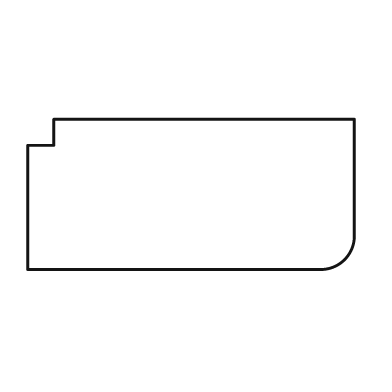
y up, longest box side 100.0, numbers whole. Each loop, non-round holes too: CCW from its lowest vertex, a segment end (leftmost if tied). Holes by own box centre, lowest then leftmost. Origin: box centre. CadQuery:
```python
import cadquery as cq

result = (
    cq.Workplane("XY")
    .moveTo(-50.0, -23.0)
    .lineTo(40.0, -23.0)
    .threePointArc((47.0, -20.0), (50.0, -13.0))
    .lineTo(50.0, 23.0)
    .lineTo(-42.0, 23.0)
    .lineTo(-42.0, 15.0)
    .lineTo(-50.0, 15.0)
    .close()
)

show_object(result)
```